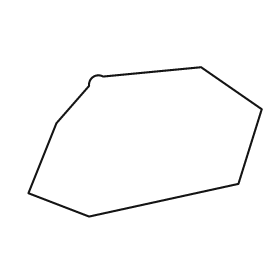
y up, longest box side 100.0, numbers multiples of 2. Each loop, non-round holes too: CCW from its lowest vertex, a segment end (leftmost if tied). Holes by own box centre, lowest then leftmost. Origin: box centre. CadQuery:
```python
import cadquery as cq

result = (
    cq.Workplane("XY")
    .moveTo(-24.0, -32.0)
    .lineTo(40.0, -18.0)
    .lineTo(50.0, 14.0)
    .lineTo(24.0, 32.0)
    .lineTo(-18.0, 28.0)
    .threePointArc((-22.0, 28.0), (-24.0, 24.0))
    .lineTo(-38.0, 8.0)
    .lineTo(-50.0, -22.0)
    .close()
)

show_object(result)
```